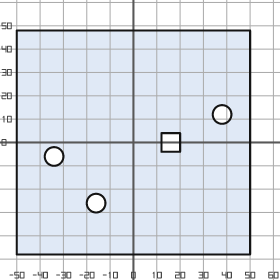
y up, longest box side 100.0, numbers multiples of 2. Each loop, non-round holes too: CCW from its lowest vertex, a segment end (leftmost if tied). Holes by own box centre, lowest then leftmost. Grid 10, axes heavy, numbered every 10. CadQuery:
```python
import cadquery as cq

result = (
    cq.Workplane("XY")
    .moveTo(-50.0, -48.0)
    .lineTo(50.0, -48.0)
    .lineTo(50.0, 48.0)
    .lineTo(-50.0, 48.0)
    .close()
    .moveTo(-16.0, -26.0)
    .circle(4.0)
    .moveTo(-34.0, -6.0)
    .circle(4.0)
    .moveTo(12.0, -4.0)
    .lineTo(20.0, -4.0)
    .lineTo(20.0, 4.0)
    .lineTo(12.0, 4.0)
    .close()
    .moveTo(38.0, 12.0)
    .circle(4.0)
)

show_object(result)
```